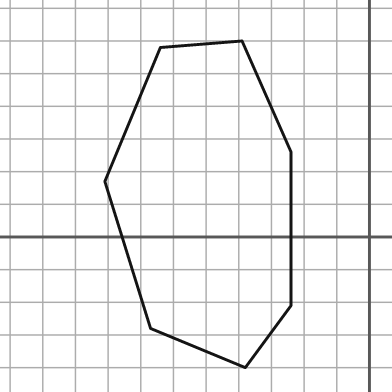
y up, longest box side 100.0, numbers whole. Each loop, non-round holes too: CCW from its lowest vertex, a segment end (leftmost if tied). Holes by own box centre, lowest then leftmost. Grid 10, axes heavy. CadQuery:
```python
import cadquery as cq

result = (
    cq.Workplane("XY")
    .moveTo(-38.0, -40.0)
    .lineTo(-24.0, -21.0)
    .lineTo(-24.0, 26.0)
    .lineTo(-39.0, 60.0)
    .lineTo(-64.0, 58.0)
    .lineTo(-81.0, 17.0)
    .lineTo(-67.0, -28.0)
    .close()
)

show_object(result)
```